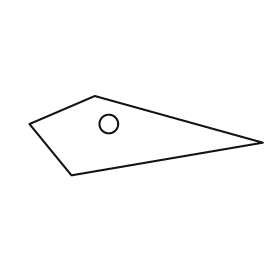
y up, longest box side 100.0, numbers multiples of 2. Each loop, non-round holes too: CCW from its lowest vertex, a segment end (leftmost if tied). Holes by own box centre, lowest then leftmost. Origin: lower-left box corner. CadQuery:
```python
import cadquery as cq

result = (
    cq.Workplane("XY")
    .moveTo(18.0, 0.0)
    .lineTo(100.0, 14.0)
    .lineTo(28.0, 34.0)
    .lineTo(0.0, 22.0)
    .close()
    .moveTo(34.0, 22.0)
    .circle(4.0)
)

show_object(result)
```